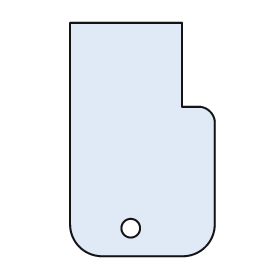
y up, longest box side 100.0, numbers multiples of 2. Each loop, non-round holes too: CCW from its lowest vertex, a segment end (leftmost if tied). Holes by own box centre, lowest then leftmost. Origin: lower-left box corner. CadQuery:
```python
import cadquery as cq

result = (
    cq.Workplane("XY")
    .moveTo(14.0, 0.0)
    .lineTo(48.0, 0.0)
    .threePointArc((58.0, 4.0), (62.0, 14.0))
    .lineTo(62.0, 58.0)
    .threePointArc((60.0, 62.0), (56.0, 64.0))
    .lineTo(48.0, 64.0)
    .lineTo(48.0, 100.0)
    .lineTo(0.0, 100.0)
    .lineTo(0.0, 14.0)
    .threePointArc((4.0, 4.0), (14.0, 0.0))
    .close()
    .moveTo(26.0, 12.0)
    .circle(4.0)
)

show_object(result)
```